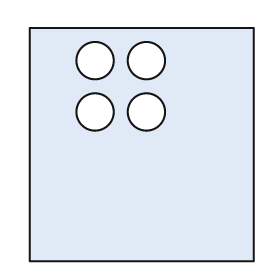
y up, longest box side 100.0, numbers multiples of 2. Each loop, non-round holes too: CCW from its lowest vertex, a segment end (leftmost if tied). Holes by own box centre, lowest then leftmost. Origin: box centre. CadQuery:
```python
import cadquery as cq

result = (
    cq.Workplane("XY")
    .moveTo(-48.0, -50.0)
    .lineTo(48.0, -50.0)
    .lineTo(48.0, 50.0)
    .lineTo(-48.0, 50.0)
    .close()
    .moveTo(-20.0, 14.0)
    .circle(8.0)
    .moveTo(2.0, 14.0)
    .circle(8.0)
    .moveTo(-20.0, 36.0)
    .circle(8.0)
    .moveTo(2.0, 36.0)
    .circle(8.0)
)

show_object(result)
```